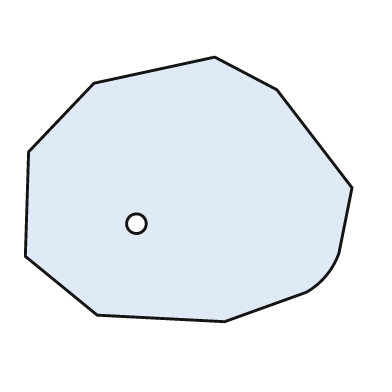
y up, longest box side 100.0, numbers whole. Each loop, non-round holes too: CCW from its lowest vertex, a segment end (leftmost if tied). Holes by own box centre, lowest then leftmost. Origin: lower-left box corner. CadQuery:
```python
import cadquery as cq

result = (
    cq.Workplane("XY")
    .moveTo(61.0, 0.0)
    .lineTo(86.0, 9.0)
    .threePointArc((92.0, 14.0), (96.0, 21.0))
    .lineTo(100.0, 41.0)
    .lineTo(77.0, 71.0)
    .lineTo(58.0, 81.0)
    .lineTo(21.0, 73.0)
    .lineTo(1.0, 52.0)
    .lineTo(0.0, 20.0)
    .lineTo(22.0, 2.0)
    .close()
    .moveTo(34.0, 30.0)
    .circle(3.0)
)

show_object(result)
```